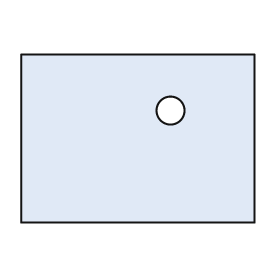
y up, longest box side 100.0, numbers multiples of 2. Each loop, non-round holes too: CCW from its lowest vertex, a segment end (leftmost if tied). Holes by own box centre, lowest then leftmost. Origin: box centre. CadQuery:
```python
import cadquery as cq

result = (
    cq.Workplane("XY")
    .moveTo(-50.0, -36.0)
    .lineTo(50.0, -36.0)
    .lineTo(50.0, 36.0)
    .lineTo(-50.0, 36.0)
    .close()
    .moveTo(14.0, 12.0)
    .circle(6.0)
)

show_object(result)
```